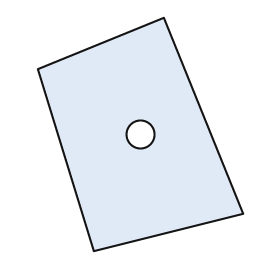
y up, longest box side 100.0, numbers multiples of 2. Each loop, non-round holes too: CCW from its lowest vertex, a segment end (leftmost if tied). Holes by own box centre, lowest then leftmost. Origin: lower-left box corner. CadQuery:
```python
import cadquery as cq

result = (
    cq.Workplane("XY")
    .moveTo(24.0, 0.0)
    .lineTo(88.0, 16.0)
    .lineTo(54.0, 100.0)
    .lineTo(0.0, 78.0)
    .close()
    .moveTo(44.0, 50.0)
    .circle(6.0)
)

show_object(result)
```